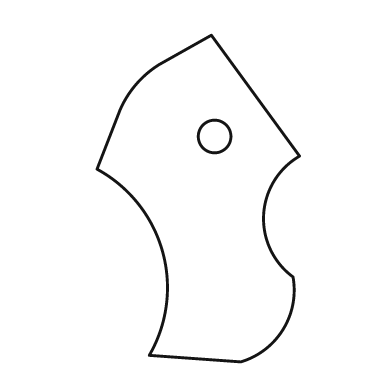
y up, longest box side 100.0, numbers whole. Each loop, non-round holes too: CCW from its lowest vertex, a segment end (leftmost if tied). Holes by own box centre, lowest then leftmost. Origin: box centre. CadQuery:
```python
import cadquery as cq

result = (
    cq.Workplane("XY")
    .moveTo(13.0, -50.0)
    .threePointArc((26.0, -40.0), (29.0, -24.0))
    .threePointArc((20.0, -5.0), (31.0, 13.0))
    .lineTo(4.0, 50.0)
    .lineTo(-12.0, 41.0)
    .threePointArc((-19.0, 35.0), (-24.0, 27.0))
    .lineTo(-31.0, 9.0)
    .threePointArc((-11.0, -16.0), (-15.0, -48.0))
    .close()
    .moveTo(5.0, 19.0)
    .circle(5.0)
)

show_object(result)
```